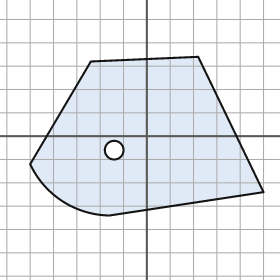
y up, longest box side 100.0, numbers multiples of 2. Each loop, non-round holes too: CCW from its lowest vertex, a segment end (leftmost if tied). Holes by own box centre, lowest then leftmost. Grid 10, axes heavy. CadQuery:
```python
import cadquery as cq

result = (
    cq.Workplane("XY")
    .moveTo(-16.0, -34.0)
    .lineTo(50.0, -24.0)
    .lineTo(22.0, 34.0)
    .lineTo(-24.0, 32.0)
    .lineTo(-50.0, -12.0)
    .threePointArc((-36.0, -28.0), (-16.0, -34.0))
    .close()
    .moveTo(-14.0, -6.0)
    .circle(4.0)
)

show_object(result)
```